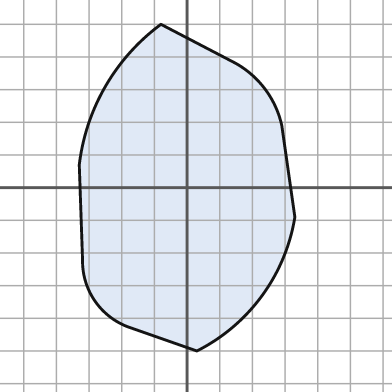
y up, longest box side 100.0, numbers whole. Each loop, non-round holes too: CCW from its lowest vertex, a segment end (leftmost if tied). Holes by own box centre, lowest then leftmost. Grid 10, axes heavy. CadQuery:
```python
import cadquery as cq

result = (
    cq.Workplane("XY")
    .moveTo(3.0, -50.0)
    .threePointArc((23.0, -33.0), (33.0, -9.0))
    .lineTo(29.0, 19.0)
    .threePointArc((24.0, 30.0), (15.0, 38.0))
    .lineTo(-8.0, 50.0)
    .threePointArc((-25.0, 31.0), (-33.0, 7.0))
    .lineTo(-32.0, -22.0)
    .threePointArc((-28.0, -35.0), (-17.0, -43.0))
    .close()
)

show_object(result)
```